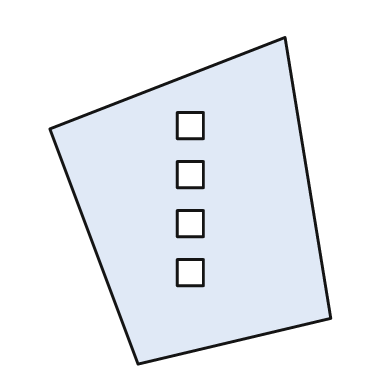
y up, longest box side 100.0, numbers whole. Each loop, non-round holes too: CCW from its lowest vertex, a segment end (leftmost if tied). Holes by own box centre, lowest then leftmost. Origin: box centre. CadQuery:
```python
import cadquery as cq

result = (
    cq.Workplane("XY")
    .moveTo(-16.0, -50.0)
    .lineTo(43.0, -36.0)
    .lineTo(29.0, 50.0)
    .lineTo(-43.0, 22.0)
    .close()
    .moveTo(-4.0, -26.0)
    .lineTo(4.0, -26.0)
    .lineTo(4.0, -18.0)
    .lineTo(-4.0, -18.0)
    .close()
    .moveTo(-4.0, -11.0)
    .lineTo(4.0, -11.0)
    .lineTo(4.0, -3.0)
    .lineTo(-4.0, -3.0)
    .close()
    .moveTo(-4.0, 4.0)
    .lineTo(4.0, 4.0)
    .lineTo(4.0, 12.0)
    .lineTo(-4.0, 12.0)
    .close()
    .moveTo(-4.0, 19.0)
    .lineTo(4.0, 19.0)
    .lineTo(4.0, 27.0)
    .lineTo(-4.0, 27.0)
    .close()
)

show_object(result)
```